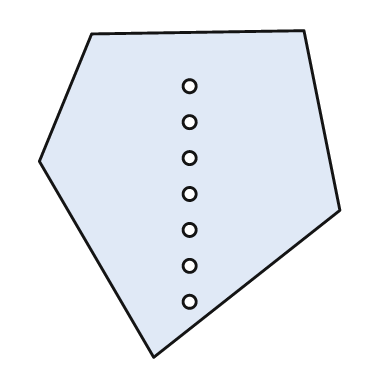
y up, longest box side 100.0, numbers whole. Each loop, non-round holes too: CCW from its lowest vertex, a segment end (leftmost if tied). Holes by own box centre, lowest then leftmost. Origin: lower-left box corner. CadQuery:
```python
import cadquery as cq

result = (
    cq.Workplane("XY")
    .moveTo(35.0, 0.0)
    .lineTo(92.0, 45.0)
    .lineTo(81.0, 100.0)
    .lineTo(16.0, 99.0)
    .lineTo(0.0, 60.0)
    .close()
    .moveTo(46.0, 17.0)
    .circle(2.0)
    .moveTo(46.0, 28.0)
    .circle(2.0)
    .moveTo(46.0, 39.0)
    .circle(2.0)
    .moveTo(46.0, 50.0)
    .circle(2.0)
    .moveTo(46.0, 61.0)
    .circle(2.0)
    .moveTo(46.0, 72.0)
    .circle(2.0)
    .moveTo(46.0, 83.0)
    .circle(2.0)
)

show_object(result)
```